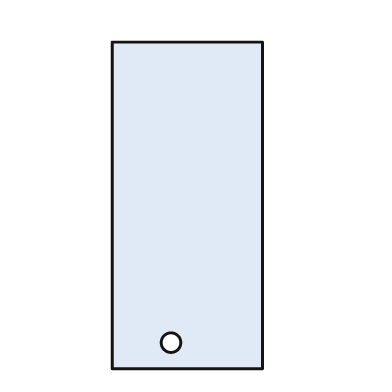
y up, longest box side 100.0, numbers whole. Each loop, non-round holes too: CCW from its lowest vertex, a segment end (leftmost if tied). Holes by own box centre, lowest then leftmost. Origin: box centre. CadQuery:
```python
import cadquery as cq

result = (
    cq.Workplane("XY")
    .moveTo(-23.0, -50.0)
    .lineTo(23.0, -50.0)
    .lineTo(23.0, 50.0)
    .lineTo(-23.0, 50.0)
    .close()
    .moveTo(-5.0, -42.0)
    .circle(3.0)
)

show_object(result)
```